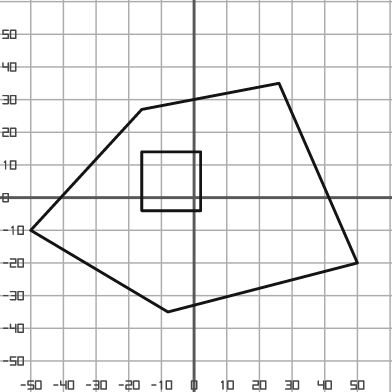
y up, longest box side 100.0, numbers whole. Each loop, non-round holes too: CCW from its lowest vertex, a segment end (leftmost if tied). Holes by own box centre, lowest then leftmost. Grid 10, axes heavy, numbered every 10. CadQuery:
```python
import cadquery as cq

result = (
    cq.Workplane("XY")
    .moveTo(-8.0, -35.0)
    .lineTo(50.0, -20.0)
    .lineTo(26.0, 35.0)
    .lineTo(-16.0, 27.0)
    .lineTo(-50.0, -10.0)
    .close()
    .moveTo(-16.0, -4.0)
    .lineTo(2.0, -4.0)
    .lineTo(2.0, 14.0)
    .lineTo(-16.0, 14.0)
    .close()
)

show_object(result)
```